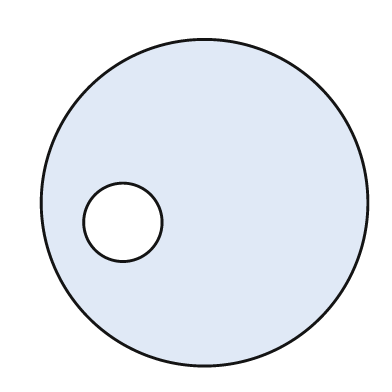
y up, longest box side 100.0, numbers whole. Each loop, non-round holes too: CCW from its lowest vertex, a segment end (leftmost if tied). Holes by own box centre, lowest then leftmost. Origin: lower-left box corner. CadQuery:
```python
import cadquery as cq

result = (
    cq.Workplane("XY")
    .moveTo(50.0, 50.0)
    .circle(50.0)
    .moveTo(25.0, 44.0)
    .circle(12.0)
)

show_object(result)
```